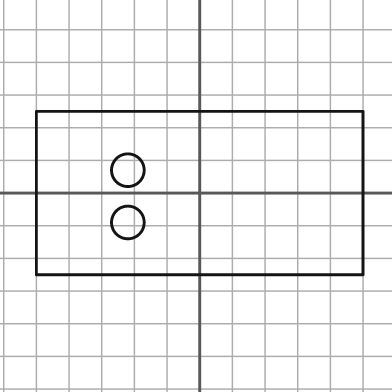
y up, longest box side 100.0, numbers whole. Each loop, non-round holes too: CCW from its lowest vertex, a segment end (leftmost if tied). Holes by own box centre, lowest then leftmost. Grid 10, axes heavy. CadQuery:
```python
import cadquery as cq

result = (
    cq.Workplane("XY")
    .moveTo(-50.0, -25.0)
    .lineTo(50.0, -25.0)
    .lineTo(50.0, 25.0)
    .lineTo(-50.0, 25.0)
    .close()
    .moveTo(-22.0, -9.0)
    .circle(5.0)
    .moveTo(-22.0, 7.0)
    .circle(5.0)
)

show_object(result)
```